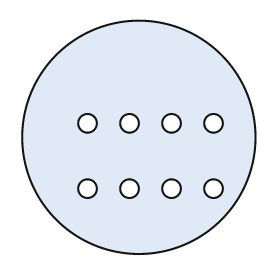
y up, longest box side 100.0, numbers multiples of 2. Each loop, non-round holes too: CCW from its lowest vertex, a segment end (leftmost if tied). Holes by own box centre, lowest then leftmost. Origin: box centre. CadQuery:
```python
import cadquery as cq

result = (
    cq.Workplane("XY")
    .moveTo(0.0, 0.0)
    .circle(50.0)
    .moveTo(-22.0, -22.0)
    .circle(4.0)
    .moveTo(-4.0, -22.0)
    .circle(4.0)
    .moveTo(14.0, -22.0)
    .circle(4.0)
    .moveTo(32.0, -22.0)
    .circle(4.0)
    .moveTo(-22.0, 6.0)
    .circle(4.0)
    .moveTo(-4.0, 6.0)
    .circle(4.0)
    .moveTo(14.0, 6.0)
    .circle(4.0)
    .moveTo(32.0, 6.0)
    .circle(4.0)
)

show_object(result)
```